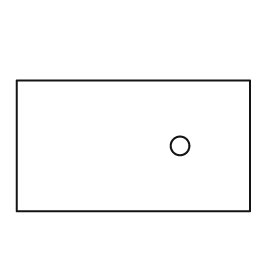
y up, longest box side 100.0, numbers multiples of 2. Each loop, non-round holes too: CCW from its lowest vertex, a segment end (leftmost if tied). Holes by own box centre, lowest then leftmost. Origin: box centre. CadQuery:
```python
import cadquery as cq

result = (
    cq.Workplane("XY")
    .moveTo(-50.0, -28.0)
    .lineTo(50.0, -28.0)
    .lineTo(50.0, 28.0)
    .lineTo(-50.0, 28.0)
    .close()
    .moveTo(20.0, 0.0)
    .circle(4.0)
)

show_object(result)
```